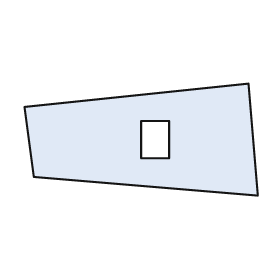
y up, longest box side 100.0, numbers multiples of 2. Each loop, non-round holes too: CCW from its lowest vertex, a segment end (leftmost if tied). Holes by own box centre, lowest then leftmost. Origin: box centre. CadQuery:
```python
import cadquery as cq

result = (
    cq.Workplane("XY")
    .moveTo(50.0, -24.0)
    .lineTo(46.0, 24.0)
    .lineTo(-50.0, 14.0)
    .lineTo(-46.0, -16.0)
    .close()
    .moveTo(0.0, -8.0)
    .lineTo(12.0, -8.0)
    .lineTo(12.0, 8.0)
    .lineTo(0.0, 8.0)
    .close()
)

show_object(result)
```